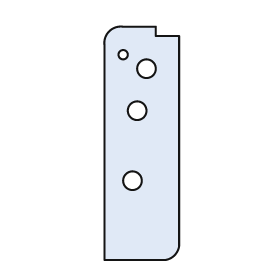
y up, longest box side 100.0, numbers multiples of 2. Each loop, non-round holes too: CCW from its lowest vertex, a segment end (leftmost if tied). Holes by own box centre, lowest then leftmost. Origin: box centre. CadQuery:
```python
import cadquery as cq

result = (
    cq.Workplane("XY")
    .moveTo(-16.0, -50.0)
    .lineTo(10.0, -50.0)
    .threePointArc((14.0, -48.0), (16.0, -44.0))
    .lineTo(16.0, 46.0)
    .lineTo(6.0, 46.0)
    .lineTo(6.0, 50.0)
    .lineTo(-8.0, 50.0)
    .threePointArc((-14.0, 48.0), (-16.0, 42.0))
    .close()
    .moveTo(-4.0, -16.0)
    .circle(4.0)
    .moveTo(-2.0, 14.0)
    .circle(4.0)
    .moveTo(2.0, 32.0)
    .circle(4.0)
    .moveTo(-8.0, 38.0)
    .circle(2.0)
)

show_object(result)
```